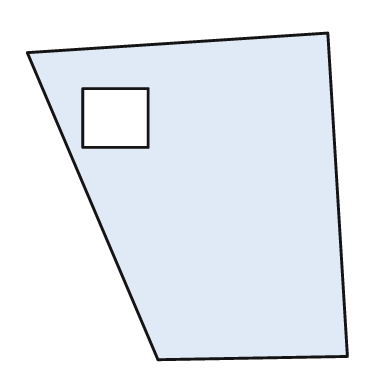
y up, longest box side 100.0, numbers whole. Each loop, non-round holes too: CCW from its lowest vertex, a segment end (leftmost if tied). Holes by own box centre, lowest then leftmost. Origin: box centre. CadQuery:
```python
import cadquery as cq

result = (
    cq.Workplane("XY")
    .moveTo(-9.0, -50.0)
    .lineTo(49.0, -49.0)
    .lineTo(43.0, 50.0)
    .lineTo(-49.0, 44.0)
    .close()
    .moveTo(-32.0, 15.0)
    .lineTo(-12.0, 15.0)
    .lineTo(-12.0, 33.0)
    .lineTo(-32.0, 33.0)
    .close()
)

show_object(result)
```